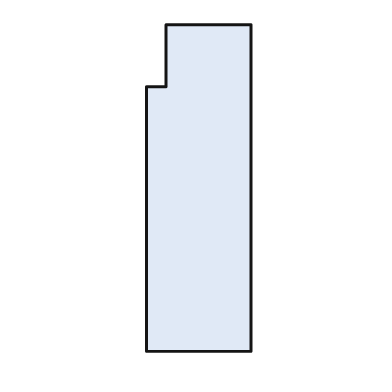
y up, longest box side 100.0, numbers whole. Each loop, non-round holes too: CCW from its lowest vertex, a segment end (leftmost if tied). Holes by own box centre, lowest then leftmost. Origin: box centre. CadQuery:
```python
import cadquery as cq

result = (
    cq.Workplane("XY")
    .moveTo(-16.0, -50.0)
    .lineTo(16.0, -50.0)
    .lineTo(16.0, 50.0)
    .lineTo(-10.0, 50.0)
    .lineTo(-10.0, 31.0)
    .lineTo(-16.0, 31.0)
    .close()
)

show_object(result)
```